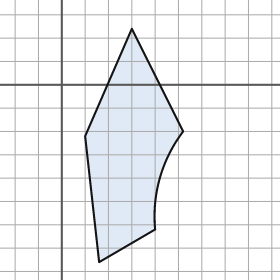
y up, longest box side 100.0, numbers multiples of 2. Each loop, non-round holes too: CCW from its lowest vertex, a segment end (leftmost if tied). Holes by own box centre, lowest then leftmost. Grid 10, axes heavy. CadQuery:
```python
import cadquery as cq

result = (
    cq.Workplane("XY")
    .moveTo(16.0, -76.0)
    .lineTo(40.0, -62.0)
    .threePointArc((42.0, -40.0), (52.0, -20.0))
    .lineTo(30.0, 24.0)
    .lineTo(10.0, -22.0)
    .close()
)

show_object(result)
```